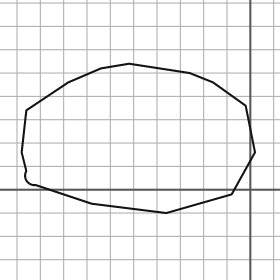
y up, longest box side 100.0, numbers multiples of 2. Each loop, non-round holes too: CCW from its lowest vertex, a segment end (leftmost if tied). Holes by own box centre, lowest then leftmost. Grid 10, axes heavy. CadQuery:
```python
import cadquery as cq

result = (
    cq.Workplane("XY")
    .moveTo(-36.0, -10.0)
    .lineTo(-8.0, -2.0)
    .lineTo(2.0, 16.0)
    .lineTo(-2.0, 36.0)
    .lineTo(-16.0, 46.0)
    .lineTo(-26.0, 50.0)
    .lineTo(-52.0, 54.0)
    .lineTo(-64.0, 52.0)
    .lineTo(-78.0, 46.0)
    .lineTo(-96.0, 34.0)
    .lineTo(-98.0, 16.0)
    .lineTo(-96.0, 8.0)
    .threePointArc((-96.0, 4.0), (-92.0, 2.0))
    .lineTo(-68.0, -6.0)
    .close()
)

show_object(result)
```